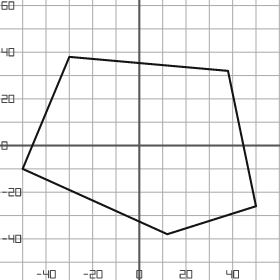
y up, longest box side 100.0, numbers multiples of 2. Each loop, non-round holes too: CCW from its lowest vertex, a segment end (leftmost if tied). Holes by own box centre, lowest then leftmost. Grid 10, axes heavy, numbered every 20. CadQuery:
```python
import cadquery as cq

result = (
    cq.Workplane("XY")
    .moveTo(12.0, -38.0)
    .lineTo(50.0, -26.0)
    .lineTo(38.0, 32.0)
    .lineTo(-30.0, 38.0)
    .lineTo(-50.0, -10.0)
    .close()
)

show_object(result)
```